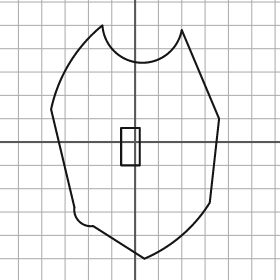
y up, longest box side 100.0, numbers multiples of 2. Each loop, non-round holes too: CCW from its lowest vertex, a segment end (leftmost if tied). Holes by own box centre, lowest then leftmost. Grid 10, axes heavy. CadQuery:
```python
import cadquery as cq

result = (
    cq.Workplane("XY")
    .moveTo(4.0, -50.0)
    .threePointArc((20.0, -40.0), (32.0, -26.0))
    .lineTo(36.0, 10.0)
    .lineTo(20.0, 48.0)
    .threePointArc((2.0, 34.0), (-14.0, 50.0))
    .threePointArc((-28.0, 34.0), (-36.0, 14.0))
    .lineTo(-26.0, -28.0)
    .threePointArc((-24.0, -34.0), (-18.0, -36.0))
    .close()
    .moveTo(-6.0, -10.0)
    .lineTo(2.0, -10.0)
    .lineTo(2.0, 6.0)
    .lineTo(-6.0, 6.0)
    .close()
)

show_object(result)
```